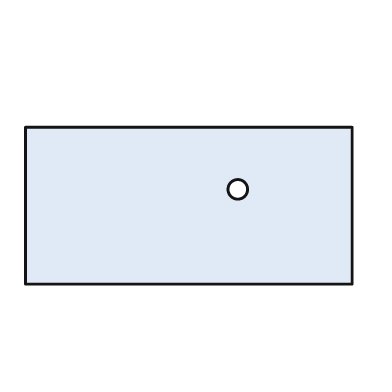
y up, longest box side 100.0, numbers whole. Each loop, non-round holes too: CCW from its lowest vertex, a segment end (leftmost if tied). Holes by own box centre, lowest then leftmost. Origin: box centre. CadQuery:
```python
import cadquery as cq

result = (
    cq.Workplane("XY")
    .moveTo(-50.0, -24.0)
    .lineTo(50.0, -24.0)
    .lineTo(50.0, 24.0)
    .lineTo(-50.0, 24.0)
    .close()
    .moveTo(15.0, 5.0)
    .circle(3.0)
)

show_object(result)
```